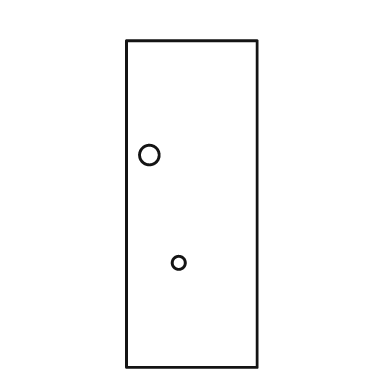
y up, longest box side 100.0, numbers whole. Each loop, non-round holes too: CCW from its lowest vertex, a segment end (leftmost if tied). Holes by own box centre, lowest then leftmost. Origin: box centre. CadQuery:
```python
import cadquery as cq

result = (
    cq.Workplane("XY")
    .moveTo(-20.0, -50.0)
    .lineTo(20.0, -50.0)
    .lineTo(20.0, 50.0)
    .lineTo(-20.0, 50.0)
    .close()
    .moveTo(-4.0, -18.0)
    .circle(2.0)
    .moveTo(-13.0, 15.0)
    .circle(3.0)
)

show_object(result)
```